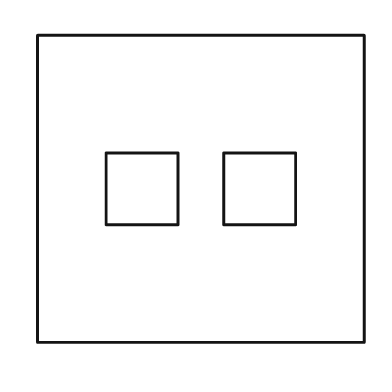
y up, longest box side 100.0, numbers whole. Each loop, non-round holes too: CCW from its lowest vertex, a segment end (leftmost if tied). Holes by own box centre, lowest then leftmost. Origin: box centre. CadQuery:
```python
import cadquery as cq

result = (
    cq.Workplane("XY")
    .moveTo(-50.0, -47.0)
    .lineTo(50.0, -47.0)
    .lineTo(50.0, 47.0)
    .lineTo(-50.0, 47.0)
    .close()
    .moveTo(-29.0, -11.0)
    .lineTo(-7.0, -11.0)
    .lineTo(-7.0, 11.0)
    .lineTo(-29.0, 11.0)
    .close()
    .moveTo(7.0, -11.0)
    .lineTo(29.0, -11.0)
    .lineTo(29.0, 11.0)
    .lineTo(7.0, 11.0)
    .close()
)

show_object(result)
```